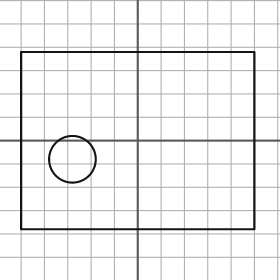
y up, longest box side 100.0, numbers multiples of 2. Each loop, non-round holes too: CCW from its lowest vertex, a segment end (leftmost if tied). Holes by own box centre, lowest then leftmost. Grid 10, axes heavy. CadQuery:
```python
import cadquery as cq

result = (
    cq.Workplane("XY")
    .moveTo(-50.0, -38.0)
    .lineTo(50.0, -38.0)
    .lineTo(50.0, 38.0)
    .lineTo(-50.0, 38.0)
    .close()
    .moveTo(-28.0, -8.0)
    .circle(10.0)
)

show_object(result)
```